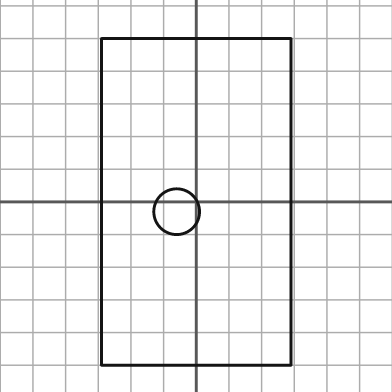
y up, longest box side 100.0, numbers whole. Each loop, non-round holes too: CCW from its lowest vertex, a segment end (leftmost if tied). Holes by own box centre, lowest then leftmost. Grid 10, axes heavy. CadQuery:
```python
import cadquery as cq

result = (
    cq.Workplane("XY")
    .moveTo(-29.0, -50.0)
    .lineTo(29.0, -50.0)
    .lineTo(29.0, 50.0)
    .lineTo(-29.0, 50.0)
    .close()
    .moveTo(-6.0, -3.0)
    .circle(7.0)
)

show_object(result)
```